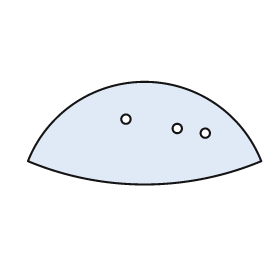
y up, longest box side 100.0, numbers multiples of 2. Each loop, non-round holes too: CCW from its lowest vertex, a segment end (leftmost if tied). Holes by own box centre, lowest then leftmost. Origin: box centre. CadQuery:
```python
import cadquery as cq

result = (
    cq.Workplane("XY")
    .moveTo(-50.0, -12.0)
    .threePointArc((0.0, -22.0), (50.0, -12.0))
    .threePointArc((0.0, 22.0), (-50.0, -12.0))
    .close()
    .moveTo(26.0, 0.0)
    .circle(2.0)
    .moveTo(14.0, 2.0)
    .circle(2.0)
    .moveTo(-8.0, 6.0)
    .circle(2.0)
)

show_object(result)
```